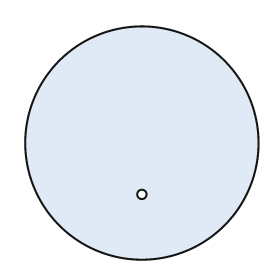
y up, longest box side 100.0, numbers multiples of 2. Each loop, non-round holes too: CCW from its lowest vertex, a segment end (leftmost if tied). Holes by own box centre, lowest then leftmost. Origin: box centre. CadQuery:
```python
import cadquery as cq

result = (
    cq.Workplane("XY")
    .moveTo(0.0, 0.0)
    .circle(50.0)
    .moveTo(0.0, -22.0)
    .circle(2.0)
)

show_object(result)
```